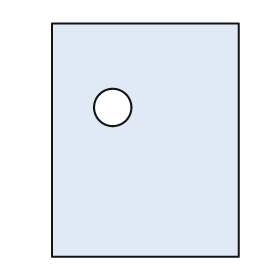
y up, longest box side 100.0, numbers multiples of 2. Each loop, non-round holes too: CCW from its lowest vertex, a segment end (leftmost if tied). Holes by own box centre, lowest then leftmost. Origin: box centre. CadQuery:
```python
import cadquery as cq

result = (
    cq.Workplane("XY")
    .moveTo(-40.0, -50.0)
    .lineTo(40.0, -50.0)
    .lineTo(40.0, 50.0)
    .lineTo(-40.0, 50.0)
    .close()
    .moveTo(-14.0, 14.0)
    .circle(8.0)
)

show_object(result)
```